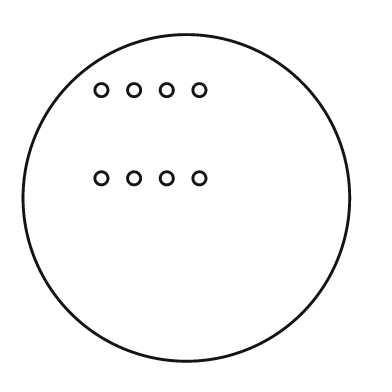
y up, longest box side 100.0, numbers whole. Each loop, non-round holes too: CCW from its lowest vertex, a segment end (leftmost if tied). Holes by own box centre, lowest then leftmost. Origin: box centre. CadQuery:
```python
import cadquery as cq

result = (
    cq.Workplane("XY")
    .moveTo(0.0, 0.0)
    .circle(50.0)
    .moveTo(-26.0, 6.0)
    .circle(2.0)
    .moveTo(-16.0, 6.0)
    .circle(2.0)
    .moveTo(-6.0, 6.0)
    .circle(2.0)
    .moveTo(4.0, 6.0)
    .circle(2.0)
    .moveTo(-26.0, 33.0)
    .circle(2.0)
    .moveTo(-16.0, 33.0)
    .circle(2.0)
    .moveTo(-6.0, 33.0)
    .circle(2.0)
    .moveTo(4.0, 33.0)
    .circle(2.0)
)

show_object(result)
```